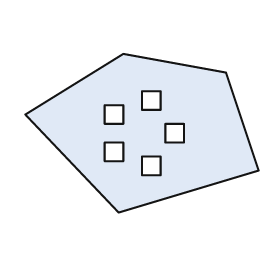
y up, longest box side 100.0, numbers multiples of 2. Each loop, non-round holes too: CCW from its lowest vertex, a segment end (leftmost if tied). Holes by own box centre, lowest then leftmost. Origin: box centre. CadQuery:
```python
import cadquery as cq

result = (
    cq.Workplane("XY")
    .moveTo(-10.0, -34.0)
    .lineTo(50.0, -16.0)
    .lineTo(36.0, 26.0)
    .lineTo(-8.0, 34.0)
    .lineTo(-50.0, 8.0)
    .close()
    .moveTo(0.0, -18.0)
    .lineTo(8.0, -18.0)
    .lineTo(8.0, -10.0)
    .lineTo(0.0, -10.0)
    .close()
    .moveTo(-16.0, -12.0)
    .lineTo(-8.0, -12.0)
    .lineTo(-8.0, -4.0)
    .lineTo(-16.0, -4.0)
    .close()
    .moveTo(10.0, -4.0)
    .lineTo(18.0, -4.0)
    .lineTo(18.0, 4.0)
    .lineTo(10.0, 4.0)
    .close()
    .moveTo(-16.0, 4.0)
    .lineTo(-8.0, 4.0)
    .lineTo(-8.0, 12.0)
    .lineTo(-16.0, 12.0)
    .close()
    .moveTo(0.0, 10.0)
    .lineTo(8.0, 10.0)
    .lineTo(8.0, 18.0)
    .lineTo(0.0, 18.0)
    .close()
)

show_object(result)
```